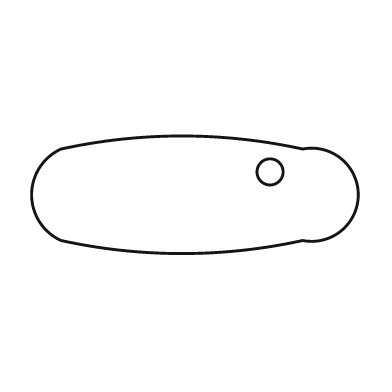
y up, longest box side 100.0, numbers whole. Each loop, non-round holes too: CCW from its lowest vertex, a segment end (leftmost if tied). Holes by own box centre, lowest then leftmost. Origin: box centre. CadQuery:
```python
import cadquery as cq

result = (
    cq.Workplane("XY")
    .moveTo(-41.0, -14.0)
    .threePointArc((-4.0, -18.0), (33.0, -14.0))
    .threePointArc((50.0, 0.0), (33.0, 14.0))
    .threePointArc((-4.0, 18.0), (-41.0, 14.0))
    .threePointArc((-50.0, 0.0), (-41.0, -14.0))
    .close()
    .moveTo(23.0, 7.0)
    .circle(4.0)
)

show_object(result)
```